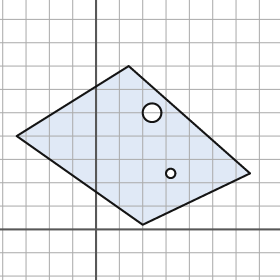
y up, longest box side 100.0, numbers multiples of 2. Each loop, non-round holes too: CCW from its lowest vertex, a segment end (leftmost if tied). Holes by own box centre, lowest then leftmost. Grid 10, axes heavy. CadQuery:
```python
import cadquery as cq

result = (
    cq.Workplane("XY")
    .moveTo(20.0, 2.0)
    .lineTo(66.0, 24.0)
    .lineTo(14.0, 70.0)
    .lineTo(-34.0, 40.0)
    .close()
    .moveTo(32.0, 24.0)
    .circle(2.0)
    .moveTo(24.0, 50.0)
    .circle(4.0)
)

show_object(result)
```